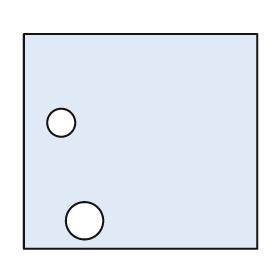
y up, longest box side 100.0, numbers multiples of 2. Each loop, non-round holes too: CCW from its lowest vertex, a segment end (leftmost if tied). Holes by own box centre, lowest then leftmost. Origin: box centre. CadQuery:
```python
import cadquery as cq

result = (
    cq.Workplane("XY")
    .moveTo(-50.0, -46.0)
    .lineTo(50.0, -46.0)
    .lineTo(50.0, 46.0)
    .lineTo(-50.0, 46.0)
    .close()
    .moveTo(-24.0, -34.0)
    .circle(8.0)
    .moveTo(-34.0, 8.0)
    .circle(6.0)
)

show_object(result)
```